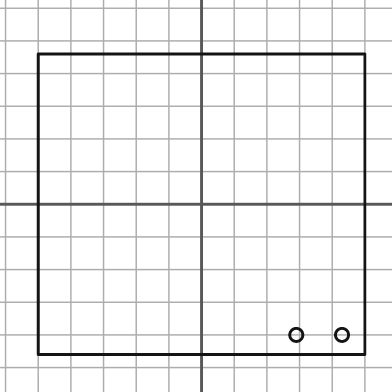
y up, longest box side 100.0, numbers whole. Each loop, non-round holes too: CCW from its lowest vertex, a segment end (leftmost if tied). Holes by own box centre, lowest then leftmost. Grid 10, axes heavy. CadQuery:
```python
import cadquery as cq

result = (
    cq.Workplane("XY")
    .moveTo(-50.0, -46.0)
    .lineTo(50.0, -46.0)
    .lineTo(50.0, 46.0)
    .lineTo(-50.0, 46.0)
    .close()
    .moveTo(29.0, -40.0)
    .circle(2.0)
    .moveTo(43.0, -40.0)
    .circle(2.0)
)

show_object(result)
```